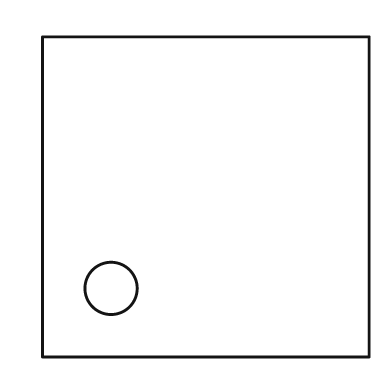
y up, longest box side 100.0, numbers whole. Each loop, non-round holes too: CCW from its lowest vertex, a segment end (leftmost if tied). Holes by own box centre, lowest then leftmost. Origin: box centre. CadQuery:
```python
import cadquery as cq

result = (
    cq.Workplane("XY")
    .moveTo(-50.0, -49.0)
    .lineTo(50.0, -49.0)
    .lineTo(50.0, 49.0)
    .lineTo(-50.0, 49.0)
    .close()
    .moveTo(-29.0, -28.0)
    .circle(8.0)
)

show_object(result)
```